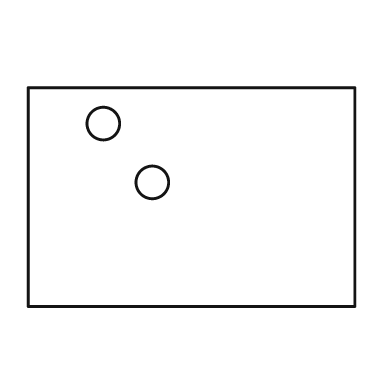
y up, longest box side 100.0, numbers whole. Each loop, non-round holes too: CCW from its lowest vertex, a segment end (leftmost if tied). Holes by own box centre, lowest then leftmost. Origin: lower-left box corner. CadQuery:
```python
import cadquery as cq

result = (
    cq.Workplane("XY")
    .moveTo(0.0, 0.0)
    .lineTo(100.0, 0.0)
    .lineTo(100.0, 67.0)
    .lineTo(0.0, 67.0)
    .close()
    .moveTo(38.0, 38.0)
    .circle(5.0)
    .moveTo(23.0, 56.0)
    .circle(5.0)
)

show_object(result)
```